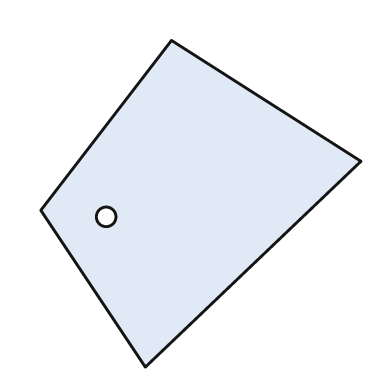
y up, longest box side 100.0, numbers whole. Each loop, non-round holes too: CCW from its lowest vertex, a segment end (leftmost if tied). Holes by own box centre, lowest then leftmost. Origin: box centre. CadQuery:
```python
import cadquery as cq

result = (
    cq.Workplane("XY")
    .moveTo(-17.0, -50.0)
    .lineTo(49.0, 13.0)
    .lineTo(-9.0, 50.0)
    .lineTo(-49.0, -2.0)
    .close()
    .moveTo(-29.0, -4.0)
    .circle(3.0)
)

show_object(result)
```